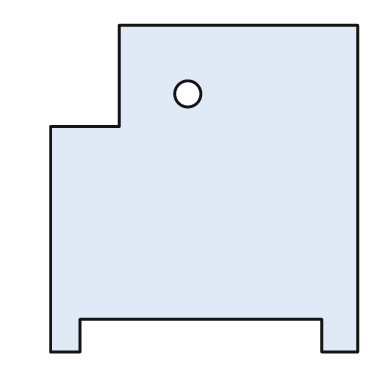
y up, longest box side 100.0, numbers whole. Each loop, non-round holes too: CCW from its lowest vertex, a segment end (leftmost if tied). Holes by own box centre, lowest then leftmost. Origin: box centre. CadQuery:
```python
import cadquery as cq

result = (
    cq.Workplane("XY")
    .moveTo(-47.0, -50.0)
    .lineTo(-38.0, -50.0)
    .lineTo(-38.0, -40.0)
    .lineTo(36.0, -40.0)
    .lineTo(36.0, -50.0)
    .lineTo(47.0, -50.0)
    .lineTo(47.0, 50.0)
    .lineTo(-26.0, 50.0)
    .lineTo(-26.0, 19.0)
    .lineTo(-47.0, 19.0)
    .close()
    .moveTo(-5.0, 29.0)
    .circle(4.0)
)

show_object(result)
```